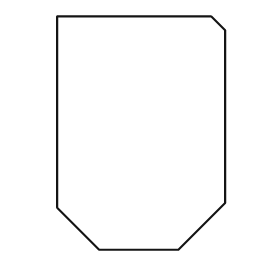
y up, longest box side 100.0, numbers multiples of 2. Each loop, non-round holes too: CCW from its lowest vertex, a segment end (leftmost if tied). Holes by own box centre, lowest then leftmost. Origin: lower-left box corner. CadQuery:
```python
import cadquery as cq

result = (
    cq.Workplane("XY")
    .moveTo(18.0, 0.0)
    .lineTo(52.0, 0.0)
    .lineTo(72.0, 20.0)
    .lineTo(72.0, 94.0)
    .lineTo(66.0, 100.0)
    .lineTo(0.0, 100.0)
    .lineTo(0.0, 18.0)
    .close()
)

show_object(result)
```